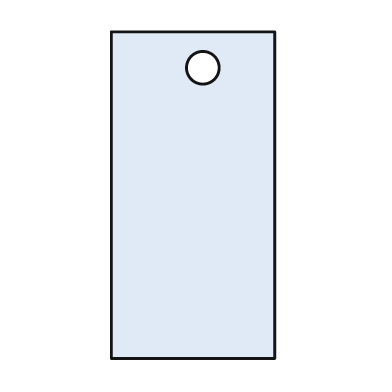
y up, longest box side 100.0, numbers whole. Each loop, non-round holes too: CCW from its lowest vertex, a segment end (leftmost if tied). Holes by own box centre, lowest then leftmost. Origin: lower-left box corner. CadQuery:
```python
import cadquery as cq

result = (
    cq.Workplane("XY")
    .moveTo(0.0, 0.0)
    .lineTo(50.0, 0.0)
    .lineTo(50.0, 100.0)
    .lineTo(0.0, 100.0)
    .close()
    .moveTo(28.0, 89.0)
    .circle(5.0)
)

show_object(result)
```